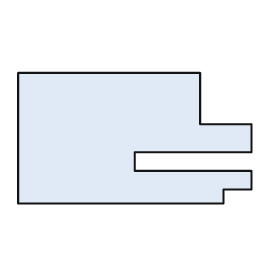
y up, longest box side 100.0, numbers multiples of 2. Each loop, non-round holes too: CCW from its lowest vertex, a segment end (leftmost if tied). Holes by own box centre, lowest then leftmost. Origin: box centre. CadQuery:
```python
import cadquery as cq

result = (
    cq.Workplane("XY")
    .moveTo(-50.0, -28.0)
    .lineTo(38.0, -28.0)
    .lineTo(38.0, -22.0)
    .lineTo(50.0, -22.0)
    .lineTo(50.0, -14.0)
    .lineTo(0.0, -14.0)
    .lineTo(0.0, -6.0)
    .lineTo(50.0, -6.0)
    .lineTo(50.0, 6.0)
    .lineTo(28.0, 6.0)
    .lineTo(28.0, 28.0)
    .lineTo(-50.0, 28.0)
    .close()
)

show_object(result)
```